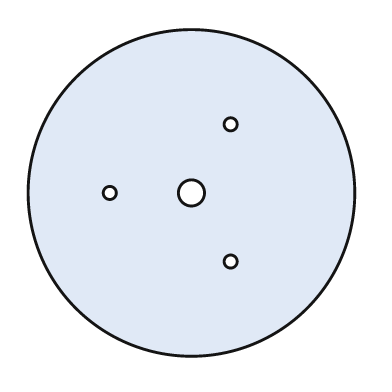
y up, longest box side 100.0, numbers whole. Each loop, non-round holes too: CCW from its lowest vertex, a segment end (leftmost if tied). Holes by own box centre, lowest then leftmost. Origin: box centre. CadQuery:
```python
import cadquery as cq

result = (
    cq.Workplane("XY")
    .moveTo(0.0, 0.0)
    .circle(50.0)
    .moveTo(12.0, -21.0)
    .circle(2.0)
    .moveTo(-25.0, 0.0)
    .circle(2.0)
    .moveTo(0.0, 0.0)
    .circle(4.0)
    .moveTo(12.0, 21.0)
    .circle(2.0)
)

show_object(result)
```